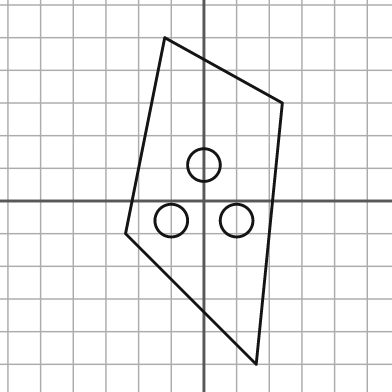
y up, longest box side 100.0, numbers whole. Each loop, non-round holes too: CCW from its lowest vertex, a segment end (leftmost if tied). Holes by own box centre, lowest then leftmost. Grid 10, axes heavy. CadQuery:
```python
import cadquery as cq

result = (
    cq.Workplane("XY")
    .moveTo(16.0, -50.0)
    .lineTo(24.0, 30.0)
    .lineTo(-12.0, 50.0)
    .lineTo(-24.0, -10.0)
    .close()
    .moveTo(-10.0, -6.0)
    .circle(5.0)
    .moveTo(10.0, -6.0)
    .circle(5.0)
    .moveTo(0.0, 11.0)
    .circle(5.0)
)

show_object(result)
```